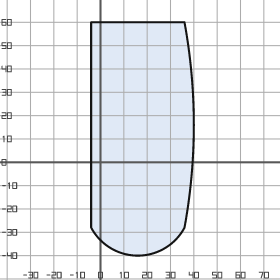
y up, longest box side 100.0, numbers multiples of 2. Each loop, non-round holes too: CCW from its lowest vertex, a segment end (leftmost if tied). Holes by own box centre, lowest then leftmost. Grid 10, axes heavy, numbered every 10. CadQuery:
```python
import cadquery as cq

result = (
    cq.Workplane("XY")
    .moveTo(-4.0, -28.0)
    .threePointArc((16.0, -40.0), (36.0, -28.0))
    .threePointArc((40.0, 16.0), (36.0, 60.0))
    .lineTo(-4.0, 60.0)
    .close()
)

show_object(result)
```